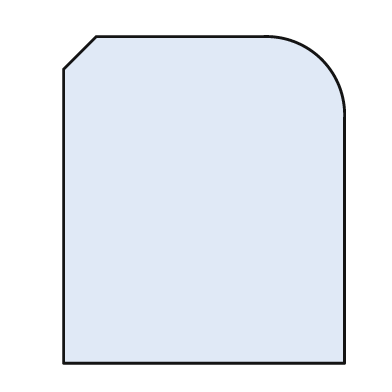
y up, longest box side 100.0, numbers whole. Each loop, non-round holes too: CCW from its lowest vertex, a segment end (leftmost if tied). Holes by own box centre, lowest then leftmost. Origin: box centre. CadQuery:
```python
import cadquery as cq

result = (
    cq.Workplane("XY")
    .moveTo(-43.0, -50.0)
    .lineTo(43.0, -50.0)
    .lineTo(43.0, 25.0)
    .threePointArc((36.0, 43.0), (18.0, 50.0))
    .lineTo(-33.0, 50.0)
    .lineTo(-43.0, 40.0)
    .close()
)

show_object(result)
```